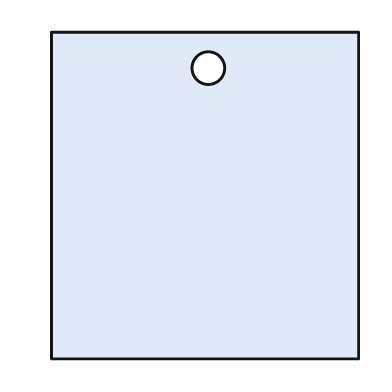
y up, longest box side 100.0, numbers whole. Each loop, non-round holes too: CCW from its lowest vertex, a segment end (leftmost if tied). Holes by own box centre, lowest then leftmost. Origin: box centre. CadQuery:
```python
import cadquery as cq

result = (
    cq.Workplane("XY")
    .moveTo(-47.0, -50.0)
    .lineTo(47.0, -50.0)
    .lineTo(47.0, 50.0)
    .lineTo(-47.0, 50.0)
    .close()
    .moveTo(1.0, 39.0)
    .circle(5.0)
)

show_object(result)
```